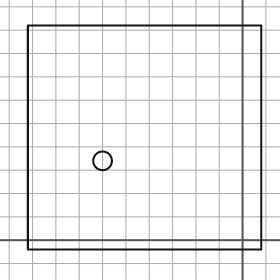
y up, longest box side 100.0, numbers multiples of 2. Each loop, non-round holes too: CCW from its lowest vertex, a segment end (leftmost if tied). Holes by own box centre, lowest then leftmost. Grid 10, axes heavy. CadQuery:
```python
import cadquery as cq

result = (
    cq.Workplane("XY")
    .moveTo(-92.0, -4.0)
    .lineTo(8.0, -4.0)
    .lineTo(8.0, 92.0)
    .lineTo(-92.0, 92.0)
    .close()
    .moveTo(-60.0, 34.0)
    .circle(4.0)
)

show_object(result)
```